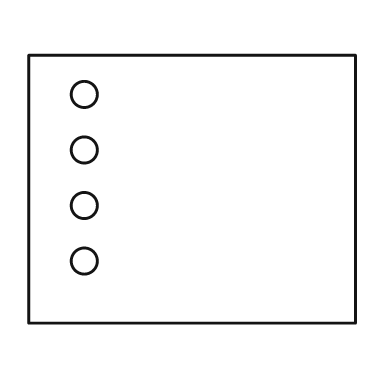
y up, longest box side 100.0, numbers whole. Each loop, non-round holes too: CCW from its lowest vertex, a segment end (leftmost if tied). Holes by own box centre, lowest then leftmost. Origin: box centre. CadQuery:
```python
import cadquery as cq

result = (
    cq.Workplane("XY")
    .moveTo(-50.0, -41.0)
    .lineTo(50.0, -41.0)
    .lineTo(50.0, 41.0)
    .lineTo(-50.0, 41.0)
    .close()
    .moveTo(-33.0, -22.0)
    .circle(4.0)
    .moveTo(-33.0, -5.0)
    .circle(4.0)
    .moveTo(-33.0, 12.0)
    .circle(4.0)
    .moveTo(-33.0, 29.0)
    .circle(4.0)
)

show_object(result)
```